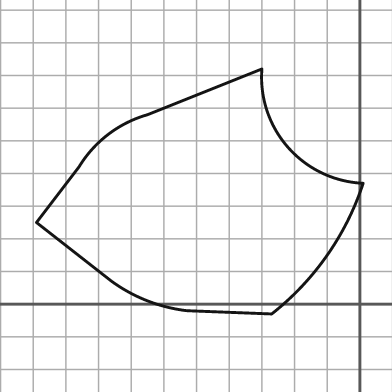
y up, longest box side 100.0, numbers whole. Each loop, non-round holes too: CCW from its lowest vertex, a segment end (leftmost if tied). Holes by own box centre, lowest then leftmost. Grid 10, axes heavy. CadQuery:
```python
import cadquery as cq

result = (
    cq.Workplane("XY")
    .moveTo(-27.0, -3.0)
    .threePointArc((-10.0, 15.0), (1.0, 37.0))
    .threePointArc((-22.0, 48.0), (-30.0, 72.0))
    .lineTo(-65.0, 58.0)
    .threePointArc((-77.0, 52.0), (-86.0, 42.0))
    .lineTo(-99.0, 25.0)
    .lineTo(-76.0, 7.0)
    .threePointArc((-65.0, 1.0), (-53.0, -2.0))
    .close()
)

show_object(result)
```